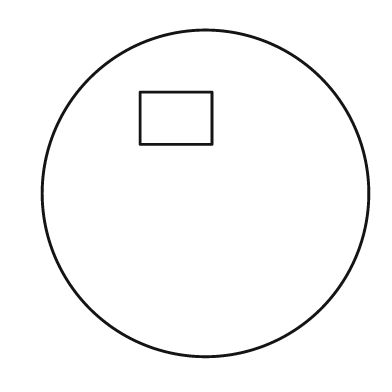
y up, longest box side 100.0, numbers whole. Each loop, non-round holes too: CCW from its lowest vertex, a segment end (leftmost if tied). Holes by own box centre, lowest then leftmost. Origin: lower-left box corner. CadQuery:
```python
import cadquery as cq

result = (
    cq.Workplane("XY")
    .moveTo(50.0, 50.0)
    .circle(50.0)
    .moveTo(30.0, 65.0)
    .lineTo(52.0, 65.0)
    .lineTo(52.0, 81.0)
    .lineTo(30.0, 81.0)
    .close()
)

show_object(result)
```